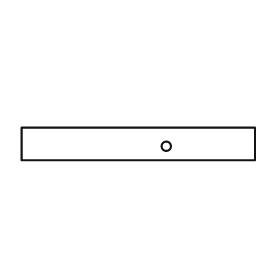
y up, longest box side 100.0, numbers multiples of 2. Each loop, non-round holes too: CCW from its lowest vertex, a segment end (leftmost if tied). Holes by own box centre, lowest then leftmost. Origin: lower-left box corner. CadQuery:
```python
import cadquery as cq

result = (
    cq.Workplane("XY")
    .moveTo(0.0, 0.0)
    .lineTo(100.0, 0.0)
    .lineTo(100.0, 14.0)
    .lineTo(0.0, 14.0)
    .close()
    .moveTo(62.0, 6.0)
    .circle(2.0)
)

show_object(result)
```